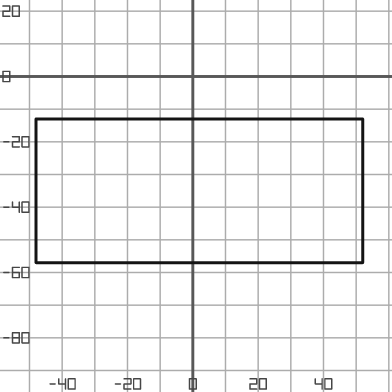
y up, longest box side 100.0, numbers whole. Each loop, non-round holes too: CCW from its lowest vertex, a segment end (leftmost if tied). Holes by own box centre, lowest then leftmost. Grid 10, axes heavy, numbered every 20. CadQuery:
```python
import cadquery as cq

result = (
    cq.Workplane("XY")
    .moveTo(-48.0, -57.0)
    .lineTo(52.0, -57.0)
    .lineTo(52.0, -13.0)
    .lineTo(-48.0, -13.0)
    .close()
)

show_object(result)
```